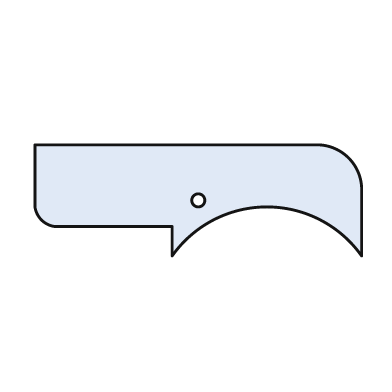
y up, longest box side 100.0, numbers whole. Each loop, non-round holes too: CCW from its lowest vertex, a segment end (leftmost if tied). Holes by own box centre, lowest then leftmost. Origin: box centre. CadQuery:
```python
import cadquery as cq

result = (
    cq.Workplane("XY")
    .moveTo(-8.0, -17.0)
    .threePointArc((21.0, -2.0), (50.0, -17.0))
    .lineTo(50.0, 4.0)
    .threePointArc((46.0, 13.0), (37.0, 17.0))
    .lineTo(-50.0, 17.0)
    .lineTo(-50.0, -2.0)
    .threePointArc((-48.0, -6.0), (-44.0, -8.0))
    .lineTo(-8.0, -8.0)
    .close()
    .moveTo(0.0, 0.0)
    .circle(2.0)
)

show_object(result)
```